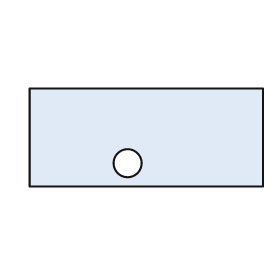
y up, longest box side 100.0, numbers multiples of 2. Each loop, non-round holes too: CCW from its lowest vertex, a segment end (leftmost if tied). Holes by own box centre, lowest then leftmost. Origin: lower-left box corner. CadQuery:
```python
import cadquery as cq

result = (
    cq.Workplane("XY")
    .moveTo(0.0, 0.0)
    .lineTo(100.0, 0.0)
    .lineTo(100.0, 42.0)
    .lineTo(0.0, 42.0)
    .close()
    .moveTo(42.0, 10.0)
    .circle(6.0)
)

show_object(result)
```